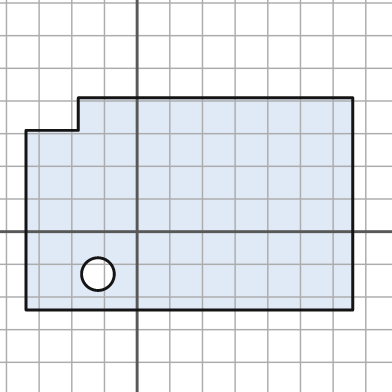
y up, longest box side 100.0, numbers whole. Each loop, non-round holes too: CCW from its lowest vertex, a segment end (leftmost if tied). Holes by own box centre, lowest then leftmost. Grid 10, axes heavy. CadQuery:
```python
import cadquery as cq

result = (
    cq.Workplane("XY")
    .moveTo(-34.0, -24.0)
    .lineTo(66.0, -24.0)
    .lineTo(66.0, 41.0)
    .lineTo(-18.0, 41.0)
    .lineTo(-18.0, 31.0)
    .lineTo(-34.0, 31.0)
    .close()
    .moveTo(-12.0, -13.0)
    .circle(5.0)
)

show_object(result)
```